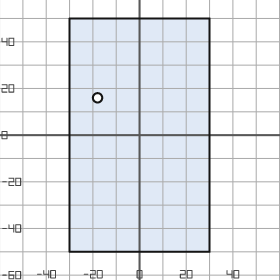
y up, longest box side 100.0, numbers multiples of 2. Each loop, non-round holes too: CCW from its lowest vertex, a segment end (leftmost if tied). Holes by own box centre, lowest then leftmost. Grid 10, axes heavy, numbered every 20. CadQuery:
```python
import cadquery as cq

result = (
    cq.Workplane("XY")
    .moveTo(-30.0, -50.0)
    .lineTo(30.0, -50.0)
    .lineTo(30.0, 50.0)
    .lineTo(-30.0, 50.0)
    .close()
    .moveTo(-18.0, 16.0)
    .circle(2.0)
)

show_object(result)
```